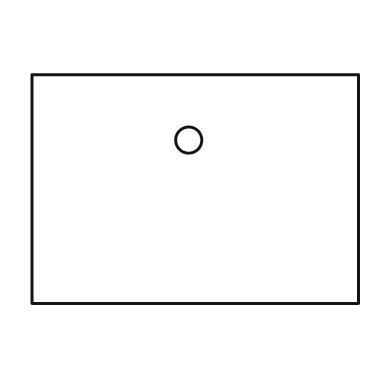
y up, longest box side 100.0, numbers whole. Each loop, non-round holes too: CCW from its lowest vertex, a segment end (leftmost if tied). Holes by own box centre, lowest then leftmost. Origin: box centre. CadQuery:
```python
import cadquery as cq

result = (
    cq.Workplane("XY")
    .moveTo(-50.0, -35.0)
    .lineTo(50.0, -35.0)
    .lineTo(50.0, 35.0)
    .lineTo(-50.0, 35.0)
    .close()
    .moveTo(-2.0, 15.0)
    .circle(4.0)
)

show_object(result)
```